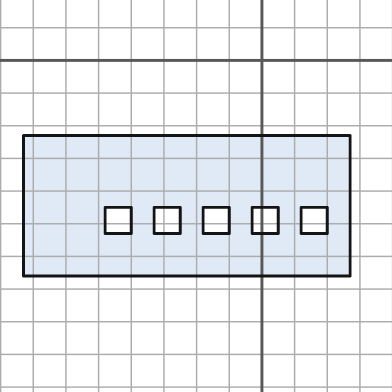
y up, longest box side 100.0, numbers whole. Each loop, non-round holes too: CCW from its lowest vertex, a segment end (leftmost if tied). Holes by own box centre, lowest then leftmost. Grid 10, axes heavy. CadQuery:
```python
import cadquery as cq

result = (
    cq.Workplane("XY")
    .moveTo(-73.0, -66.0)
    .lineTo(27.0, -66.0)
    .lineTo(27.0, -23.0)
    .lineTo(-73.0, -23.0)
    .close()
    .moveTo(-48.0, -53.0)
    .lineTo(-40.0, -53.0)
    .lineTo(-40.0, -45.0)
    .lineTo(-48.0, -45.0)
    .close()
    .moveTo(-33.0, -53.0)
    .lineTo(-25.0, -53.0)
    .lineTo(-25.0, -45.0)
    .lineTo(-33.0, -45.0)
    .close()
    .moveTo(-18.0, -53.0)
    .lineTo(-10.0, -53.0)
    .lineTo(-10.0, -45.0)
    .lineTo(-18.0, -45.0)
    .close()
    .moveTo(-3.0, -53.0)
    .lineTo(5.0, -53.0)
    .lineTo(5.0, -45.0)
    .lineTo(-3.0, -45.0)
    .close()
    .moveTo(12.0, -53.0)
    .lineTo(20.0, -53.0)
    .lineTo(20.0, -45.0)
    .lineTo(12.0, -45.0)
    .close()
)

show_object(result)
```